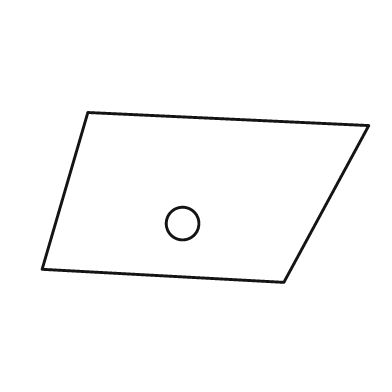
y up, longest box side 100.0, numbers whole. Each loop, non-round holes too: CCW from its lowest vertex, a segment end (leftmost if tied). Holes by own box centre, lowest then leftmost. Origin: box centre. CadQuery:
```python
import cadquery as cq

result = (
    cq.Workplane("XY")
    .moveTo(24.0, -26.0)
    .lineTo(50.0, 22.0)
    .lineTo(-36.0, 26.0)
    .lineTo(-50.0, -22.0)
    .close()
    .moveTo(-7.0, -8.0)
    .circle(5.0)
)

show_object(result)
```